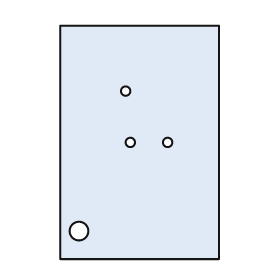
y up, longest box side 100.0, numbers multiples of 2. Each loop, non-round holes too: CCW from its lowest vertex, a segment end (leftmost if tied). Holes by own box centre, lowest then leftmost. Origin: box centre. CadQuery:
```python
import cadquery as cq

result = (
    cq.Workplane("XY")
    .moveTo(-34.0, -50.0)
    .lineTo(34.0, -50.0)
    .lineTo(34.0, 50.0)
    .lineTo(-34.0, 50.0)
    .close()
    .moveTo(-26.0, -38.0)
    .circle(4.0)
    .moveTo(-4.0, 0.0)
    .circle(2.0)
    .moveTo(12.0, 0.0)
    .circle(2.0)
    .moveTo(-6.0, 22.0)
    .circle(2.0)
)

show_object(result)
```